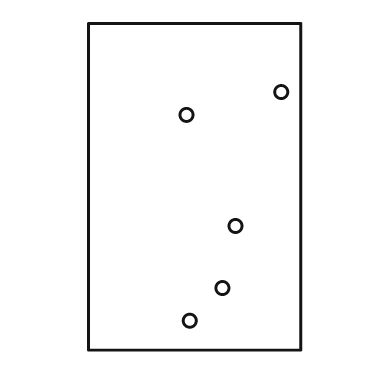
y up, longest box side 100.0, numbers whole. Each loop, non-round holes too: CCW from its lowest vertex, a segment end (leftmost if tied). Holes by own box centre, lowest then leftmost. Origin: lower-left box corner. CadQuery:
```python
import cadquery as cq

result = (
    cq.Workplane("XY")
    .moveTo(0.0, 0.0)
    .lineTo(65.0, 0.0)
    .lineTo(65.0, 100.0)
    .lineTo(0.0, 100.0)
    .close()
    .moveTo(31.0, 9.0)
    .circle(2.0)
    .moveTo(41.0, 19.0)
    .circle(2.0)
    .moveTo(45.0, 38.0)
    .circle(2.0)
    .moveTo(30.0, 72.0)
    .circle(2.0)
    .moveTo(59.0, 79.0)
    .circle(2.0)
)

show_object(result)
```